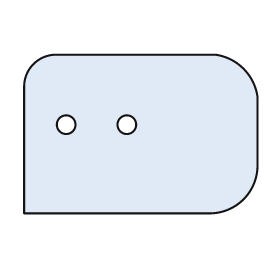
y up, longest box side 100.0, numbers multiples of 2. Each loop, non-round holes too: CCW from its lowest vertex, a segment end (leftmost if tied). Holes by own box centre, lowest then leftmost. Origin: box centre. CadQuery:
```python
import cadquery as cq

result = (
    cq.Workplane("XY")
    .moveTo(-50.0, -34.0)
    .lineTo(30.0, -34.0)
    .threePointArc((44.0, -28.0), (50.0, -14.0))
    .lineTo(50.0, 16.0)
    .threePointArc((44.0, 28.0), (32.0, 34.0))
    .lineTo(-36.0, 34.0)
    .threePointArc((-46.0, 30.0), (-50.0, 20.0))
    .close()
    .moveTo(-32.0, 4.0)
    .circle(4.0)
    .moveTo(-6.0, 4.0)
    .circle(4.0)
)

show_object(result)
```